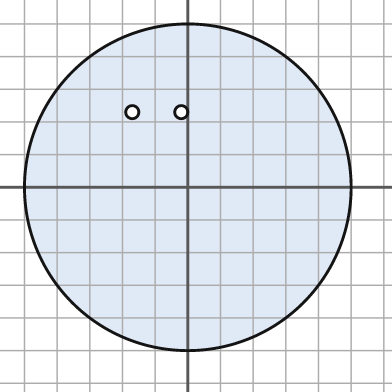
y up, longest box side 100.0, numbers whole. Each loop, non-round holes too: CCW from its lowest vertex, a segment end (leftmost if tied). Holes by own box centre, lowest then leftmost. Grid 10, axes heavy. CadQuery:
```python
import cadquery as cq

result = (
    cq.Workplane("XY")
    .moveTo(0.0, 0.0)
    .circle(50.0)
    .moveTo(-17.0, 23.0)
    .circle(2.0)
    .moveTo(-2.0, 23.0)
    .circle(2.0)
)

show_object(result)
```